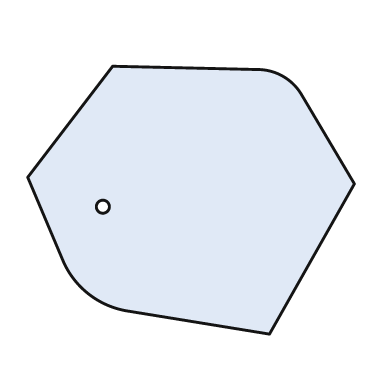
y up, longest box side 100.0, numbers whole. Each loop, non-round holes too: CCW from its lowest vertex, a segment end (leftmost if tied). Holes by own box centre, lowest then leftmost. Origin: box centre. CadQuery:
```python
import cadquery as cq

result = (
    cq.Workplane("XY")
    .moveTo(24.0, -41.0)
    .lineTo(50.0, 5.0)
    .lineTo(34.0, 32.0)
    .threePointArc((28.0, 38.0), (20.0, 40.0))
    .lineTo(-24.0, 41.0)
    .lineTo(-50.0, 7.0)
    .lineTo(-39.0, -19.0)
    .threePointArc((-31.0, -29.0), (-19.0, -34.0))
    .close()
    .moveTo(-27.0, -2.0)
    .circle(2.0)
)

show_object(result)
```